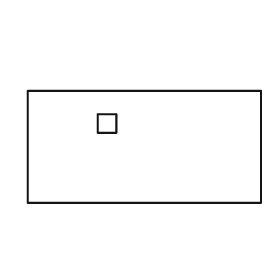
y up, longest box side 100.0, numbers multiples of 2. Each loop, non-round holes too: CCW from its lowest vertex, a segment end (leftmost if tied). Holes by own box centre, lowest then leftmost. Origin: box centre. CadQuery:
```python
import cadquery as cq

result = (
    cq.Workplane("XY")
    .moveTo(-50.0, -24.0)
    .lineTo(50.0, -24.0)
    .lineTo(50.0, 24.0)
    .lineTo(-50.0, 24.0)
    .close()
    .moveTo(-20.0, 6.0)
    .lineTo(-12.0, 6.0)
    .lineTo(-12.0, 14.0)
    .lineTo(-20.0, 14.0)
    .close()
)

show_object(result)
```